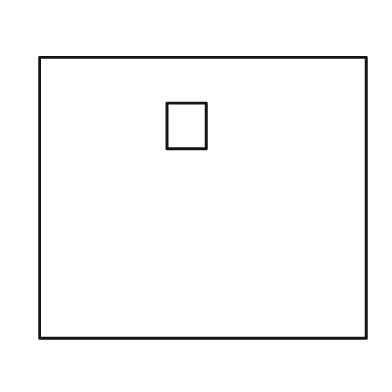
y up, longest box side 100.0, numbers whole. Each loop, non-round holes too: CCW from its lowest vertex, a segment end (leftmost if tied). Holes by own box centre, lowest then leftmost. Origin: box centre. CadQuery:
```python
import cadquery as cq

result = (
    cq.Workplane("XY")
    .moveTo(-50.0, -43.0)
    .lineTo(50.0, -43.0)
    .lineTo(50.0, 43.0)
    .lineTo(-50.0, 43.0)
    .close()
    .moveTo(-11.0, 15.0)
    .lineTo(1.0, 15.0)
    .lineTo(1.0, 29.0)
    .lineTo(-11.0, 29.0)
    .close()
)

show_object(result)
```